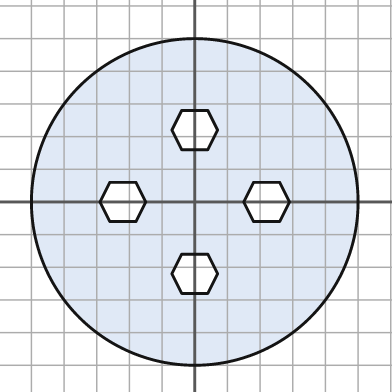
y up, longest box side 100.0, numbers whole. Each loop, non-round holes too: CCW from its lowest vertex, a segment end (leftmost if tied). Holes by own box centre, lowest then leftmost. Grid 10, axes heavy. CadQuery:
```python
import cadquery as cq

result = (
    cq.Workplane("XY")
    .moveTo(0.0, 0.0)
    .circle(50.0)
    .moveTo(-4.0, -28.0)
    .lineTo(4.0, -28.0)
    .lineTo(7.0, -22.0)
    .lineTo(4.0, -16.0)
    .lineTo(-4.0, -16.0)
    .lineTo(-7.0, -22.0)
    .close()
    .moveTo(-26.0, -6.0)
    .lineTo(-18.0, -6.0)
    .lineTo(-15.0, 0.0)
    .lineTo(-18.0, 6.0)
    .lineTo(-26.0, 6.0)
    .lineTo(-29.0, 0.0)
    .close()
    .moveTo(18.0, -6.0)
    .lineTo(26.0, -6.0)
    .lineTo(29.0, 0.0)
    .lineTo(26.0, 6.0)
    .lineTo(18.0, 6.0)
    .lineTo(15.0, 0.0)
    .close()
    .moveTo(-4.0, 16.0)
    .lineTo(4.0, 16.0)
    .lineTo(7.0, 22.0)
    .lineTo(4.0, 28.0)
    .lineTo(-4.0, 28.0)
    .lineTo(-7.0, 22.0)
    .close()
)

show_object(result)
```